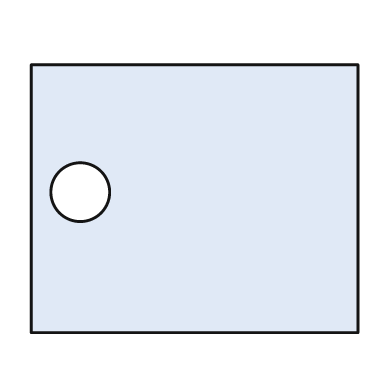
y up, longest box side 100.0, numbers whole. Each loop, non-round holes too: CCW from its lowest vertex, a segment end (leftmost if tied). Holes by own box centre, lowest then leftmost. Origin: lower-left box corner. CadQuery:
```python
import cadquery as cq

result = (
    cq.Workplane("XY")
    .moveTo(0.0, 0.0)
    .lineTo(100.0, 0.0)
    .lineTo(100.0, 82.0)
    .lineTo(0.0, 82.0)
    .close()
    .moveTo(15.0, 43.0)
    .circle(9.0)
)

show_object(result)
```